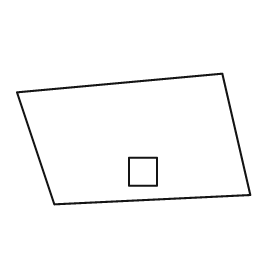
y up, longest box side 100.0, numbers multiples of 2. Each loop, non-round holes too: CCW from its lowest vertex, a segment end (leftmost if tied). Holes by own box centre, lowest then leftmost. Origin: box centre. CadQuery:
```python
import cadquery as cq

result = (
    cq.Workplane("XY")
    .moveTo(-34.0, -28.0)
    .lineTo(50.0, -24.0)
    .lineTo(38.0, 28.0)
    .lineTo(-50.0, 20.0)
    .close()
    .moveTo(-2.0, -20.0)
    .lineTo(10.0, -20.0)
    .lineTo(10.0, -8.0)
    .lineTo(-2.0, -8.0)
    .close()
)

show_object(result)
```